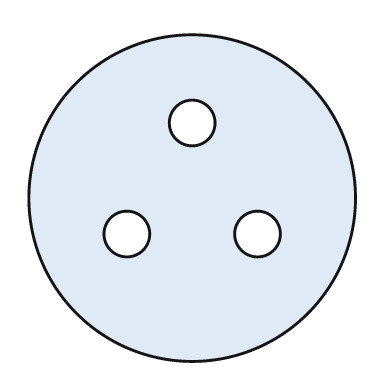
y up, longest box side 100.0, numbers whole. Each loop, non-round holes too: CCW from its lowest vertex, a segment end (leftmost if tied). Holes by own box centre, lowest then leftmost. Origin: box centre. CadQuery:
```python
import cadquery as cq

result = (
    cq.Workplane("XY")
    .moveTo(0.0, 0.0)
    .circle(50.0)
    .moveTo(-20.0, -11.0)
    .circle(7.0)
    .moveTo(20.0, -11.0)
    .circle(7.0)
    .moveTo(0.0, 23.0)
    .circle(7.0)
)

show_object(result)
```